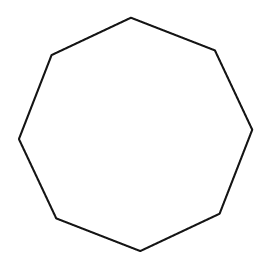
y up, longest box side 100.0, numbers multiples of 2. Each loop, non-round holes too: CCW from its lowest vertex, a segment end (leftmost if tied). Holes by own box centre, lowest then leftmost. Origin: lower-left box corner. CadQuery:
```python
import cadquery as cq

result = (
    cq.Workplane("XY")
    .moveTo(52.0, 0.0)
    .lineTo(86.0, 16.0)
    .lineTo(100.0, 52.0)
    .lineTo(84.0, 86.0)
    .lineTo(48.0, 100.0)
    .lineTo(14.0, 84.0)
    .lineTo(0.0, 48.0)
    .lineTo(16.0, 14.0)
    .close()
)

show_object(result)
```